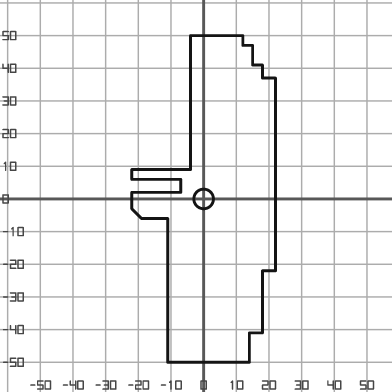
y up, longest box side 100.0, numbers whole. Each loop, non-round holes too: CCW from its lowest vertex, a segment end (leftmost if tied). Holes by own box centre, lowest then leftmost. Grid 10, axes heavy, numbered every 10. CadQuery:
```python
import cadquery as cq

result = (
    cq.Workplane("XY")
    .moveTo(-11.0, -50.0)
    .lineTo(14.0, -50.0)
    .lineTo(14.0, -41.0)
    .lineTo(18.0, -41.0)
    .lineTo(18.0, -22.0)
    .lineTo(22.0, -22.0)
    .lineTo(22.0, 37.0)
    .lineTo(18.0, 37.0)
    .lineTo(18.0, 41.0)
    .lineTo(15.0, 41.0)
    .lineTo(15.0, 47.0)
    .lineTo(12.0, 47.0)
    .lineTo(12.0, 50.0)
    .lineTo(-4.0, 50.0)
    .lineTo(-4.0, 9.0)
    .lineTo(-22.0, 9.0)
    .lineTo(-22.0, 6.0)
    .lineTo(-7.0, 6.0)
    .lineTo(-7.0, 2.0)
    .lineTo(-22.0, 2.0)
    .lineTo(-22.0, -3.0)
    .lineTo(-19.0, -6.0)
    .lineTo(-11.0, -6.0)
    .close()
    .moveTo(0.0, 0.0)
    .circle(3.0)
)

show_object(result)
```